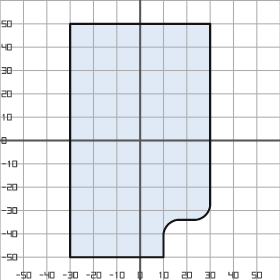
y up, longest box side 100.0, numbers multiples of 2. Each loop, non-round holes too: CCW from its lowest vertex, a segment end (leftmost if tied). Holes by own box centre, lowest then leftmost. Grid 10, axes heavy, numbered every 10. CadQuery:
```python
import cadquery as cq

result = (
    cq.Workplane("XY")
    .moveTo(-30.0, -50.0)
    .lineTo(10.0, -50.0)
    .lineTo(10.0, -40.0)
    .threePointArc((12.0, -36.0), (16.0, -34.0))
    .lineTo(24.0, -34.0)
    .threePointArc((28.0, -32.0), (30.0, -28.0))
    .lineTo(30.0, 50.0)
    .lineTo(-30.0, 50.0)
    .close()
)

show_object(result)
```